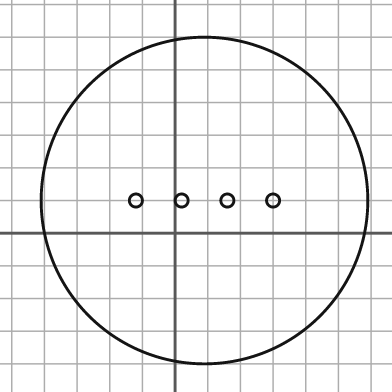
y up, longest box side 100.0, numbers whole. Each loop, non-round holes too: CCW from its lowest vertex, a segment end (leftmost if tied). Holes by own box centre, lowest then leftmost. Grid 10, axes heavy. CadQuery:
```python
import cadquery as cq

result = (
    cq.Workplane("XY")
    .moveTo(9.0, 10.0)
    .circle(50.0)
    .moveTo(-12.0, 10.0)
    .circle(2.0)
    .moveTo(2.0, 10.0)
    .circle(2.0)
    .moveTo(16.0, 10.0)
    .circle(2.0)
    .moveTo(30.0, 10.0)
    .circle(2.0)
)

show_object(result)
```